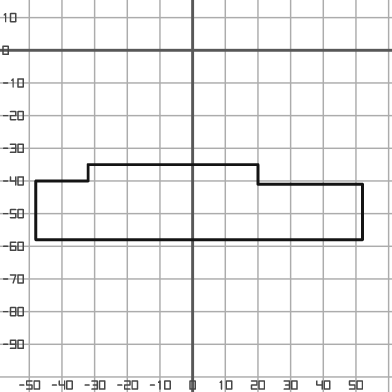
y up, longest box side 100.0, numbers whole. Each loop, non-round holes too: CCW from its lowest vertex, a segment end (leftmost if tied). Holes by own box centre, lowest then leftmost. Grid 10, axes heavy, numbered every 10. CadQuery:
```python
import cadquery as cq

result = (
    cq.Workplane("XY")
    .moveTo(-48.0, -58.0)
    .lineTo(52.0, -58.0)
    .lineTo(52.0, -41.0)
    .lineTo(20.0, -41.0)
    .lineTo(20.0, -35.0)
    .lineTo(-32.0, -35.0)
    .lineTo(-32.0, -40.0)
    .lineTo(-48.0, -40.0)
    .close()
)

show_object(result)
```